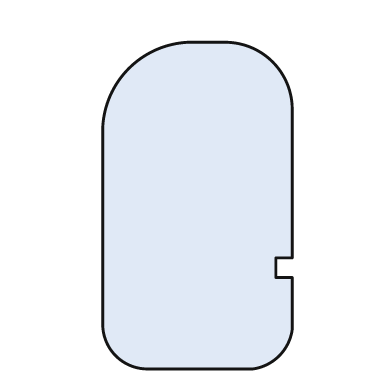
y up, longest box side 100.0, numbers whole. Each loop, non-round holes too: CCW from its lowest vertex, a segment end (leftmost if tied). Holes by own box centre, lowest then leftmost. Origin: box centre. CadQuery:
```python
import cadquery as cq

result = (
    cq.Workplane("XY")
    .moveTo(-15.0, -50.0)
    .lineTo(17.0, -50.0)
    .threePointArc((25.0, -46.0), (29.0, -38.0))
    .lineTo(29.0, -22.0)
    .lineTo(24.0, -22.0)
    .lineTo(24.0, -16.0)
    .lineTo(29.0, -16.0)
    .lineTo(29.0, 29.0)
    .threePointArc((23.0, 44.0), (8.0, 50.0))
    .lineTo(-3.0, 50.0)
    .threePointArc((-21.0, 42.0), (-29.0, 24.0))
    .lineTo(-29.0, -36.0)
    .threePointArc((-25.0, -46.0), (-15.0, -50.0))
    .close()
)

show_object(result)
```